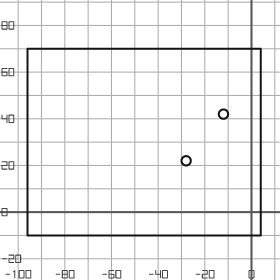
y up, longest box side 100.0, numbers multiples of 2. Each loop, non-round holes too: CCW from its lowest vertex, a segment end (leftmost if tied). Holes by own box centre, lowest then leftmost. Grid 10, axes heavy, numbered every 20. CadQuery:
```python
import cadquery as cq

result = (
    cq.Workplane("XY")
    .moveTo(-96.0, -10.0)
    .lineTo(4.0, -10.0)
    .lineTo(4.0, 70.0)
    .lineTo(-96.0, 70.0)
    .close()
    .moveTo(-28.0, 22.0)
    .circle(2.0)
    .moveTo(-12.0, 42.0)
    .circle(2.0)
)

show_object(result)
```